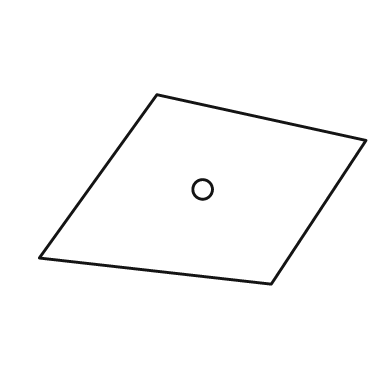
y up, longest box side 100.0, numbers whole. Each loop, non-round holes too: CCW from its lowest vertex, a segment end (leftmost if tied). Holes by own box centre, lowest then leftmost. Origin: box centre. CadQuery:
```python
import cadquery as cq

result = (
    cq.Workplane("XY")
    .moveTo(21.0, -29.0)
    .lineTo(50.0, 15.0)
    .lineTo(-14.0, 29.0)
    .lineTo(-50.0, -21.0)
    .close()
    .moveTo(0.0, 0.0)
    .circle(3.0)
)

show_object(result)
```